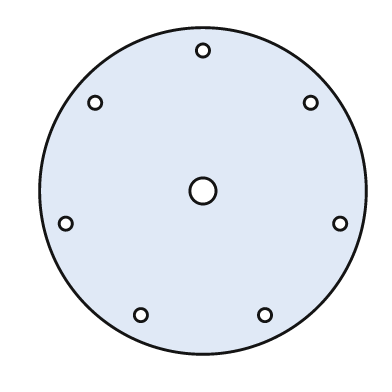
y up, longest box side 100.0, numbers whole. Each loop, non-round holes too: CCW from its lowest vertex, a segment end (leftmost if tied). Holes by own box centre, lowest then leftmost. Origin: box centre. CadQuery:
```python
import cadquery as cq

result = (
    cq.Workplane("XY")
    .moveTo(0.0, 0.0)
    .circle(50.0)
    .moveTo(-19.0, -38.0)
    .circle(2.0)
    .moveTo(19.0, -38.0)
    .circle(2.0)
    .moveTo(-42.0, -10.0)
    .circle(2.0)
    .moveTo(42.0, -10.0)
    .circle(2.0)
    .moveTo(0.0, 0.0)
    .circle(4.0)
    .moveTo(-33.0, 27.0)
    .circle(2.0)
    .moveTo(33.0, 27.0)
    .circle(2.0)
    .moveTo(0.0, 43.0)
    .circle(2.0)
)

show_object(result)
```